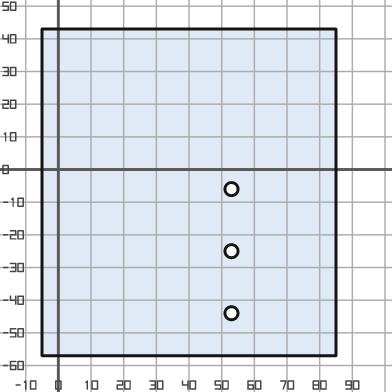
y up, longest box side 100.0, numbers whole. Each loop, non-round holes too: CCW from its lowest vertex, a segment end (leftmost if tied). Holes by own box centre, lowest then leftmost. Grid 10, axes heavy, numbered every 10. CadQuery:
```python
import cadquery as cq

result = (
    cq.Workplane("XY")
    .moveTo(-5.0, -57.0)
    .lineTo(85.0, -57.0)
    .lineTo(85.0, 43.0)
    .lineTo(-5.0, 43.0)
    .close()
    .moveTo(53.0, -44.0)
    .circle(2.0)
    .moveTo(53.0, -25.0)
    .circle(2.0)
    .moveTo(53.0, -6.0)
    .circle(2.0)
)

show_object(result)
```